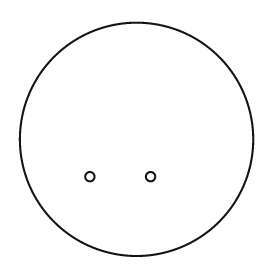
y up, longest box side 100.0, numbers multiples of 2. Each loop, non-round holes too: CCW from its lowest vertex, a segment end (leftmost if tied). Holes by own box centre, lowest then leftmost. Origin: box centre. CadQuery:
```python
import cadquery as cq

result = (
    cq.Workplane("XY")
    .moveTo(0.0, 0.0)
    .circle(50.0)
    .moveTo(-20.0, -16.0)
    .circle(2.0)
    .moveTo(6.0, -16.0)
    .circle(2.0)
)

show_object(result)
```